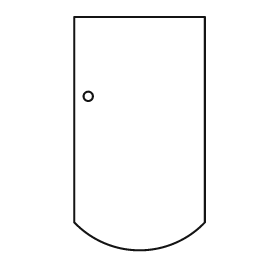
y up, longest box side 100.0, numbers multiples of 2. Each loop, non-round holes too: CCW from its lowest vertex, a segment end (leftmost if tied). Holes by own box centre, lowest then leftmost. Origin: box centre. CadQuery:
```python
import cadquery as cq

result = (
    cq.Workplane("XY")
    .moveTo(-28.0, -38.0)
    .threePointArc((0.0, -50.0), (28.0, -38.0))
    .lineTo(28.0, 50.0)
    .lineTo(-28.0, 50.0)
    .close()
    .moveTo(-22.0, 16.0)
    .circle(2.0)
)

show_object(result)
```